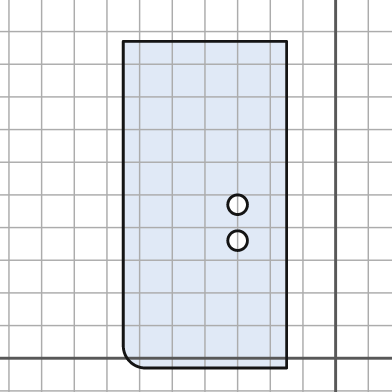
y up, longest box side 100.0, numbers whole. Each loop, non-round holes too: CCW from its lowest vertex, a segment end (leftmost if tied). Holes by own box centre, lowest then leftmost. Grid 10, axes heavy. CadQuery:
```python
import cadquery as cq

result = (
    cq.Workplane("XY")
    .moveTo(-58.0, -3.0)
    .lineTo(-15.0, -3.0)
    .lineTo(-15.0, 97.0)
    .lineTo(-65.0, 97.0)
    .lineTo(-65.0, 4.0)
    .threePointArc((-63.0, -1.0), (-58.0, -3.0))
    .close()
    .moveTo(-30.0, 36.0)
    .circle(3.0)
    .moveTo(-30.0, 47.0)
    .circle(3.0)
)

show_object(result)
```